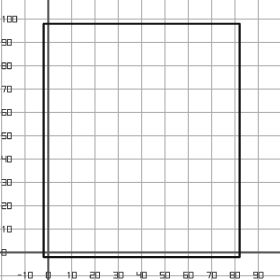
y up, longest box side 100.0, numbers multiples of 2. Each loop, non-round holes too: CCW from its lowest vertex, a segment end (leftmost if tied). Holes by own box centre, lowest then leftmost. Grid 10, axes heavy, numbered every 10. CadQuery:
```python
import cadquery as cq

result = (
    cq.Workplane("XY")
    .moveTo(-2.0, -2.0)
    .lineTo(82.0, -2.0)
    .lineTo(82.0, 98.0)
    .lineTo(-2.0, 98.0)
    .close()
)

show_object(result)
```